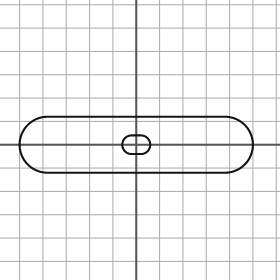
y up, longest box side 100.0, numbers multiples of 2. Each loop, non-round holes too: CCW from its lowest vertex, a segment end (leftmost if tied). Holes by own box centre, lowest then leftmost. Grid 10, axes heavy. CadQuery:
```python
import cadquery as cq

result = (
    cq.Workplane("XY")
    .moveTo(-38.0, -12.0)
    .lineTo(38.0, -12.0)
    .threePointArc((50.0, 0.0), (38.0, 12.0))
    .lineTo(-38.0, 12.0)
    .threePointArc((-50.0, 0.0), (-38.0, -12.0))
    .close()
    .moveTo(-2.0, -4.0)
    .lineTo(2.0, -4.0)
    .threePointArc((6.0, 0.0), (2.0, 4.0))
    .lineTo(-2.0, 4.0)
    .threePointArc((-6.0, 0.0), (-2.0, -4.0))
    .close()
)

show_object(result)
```